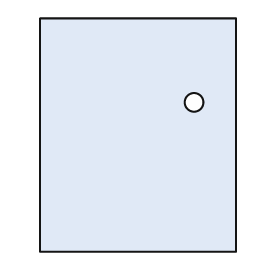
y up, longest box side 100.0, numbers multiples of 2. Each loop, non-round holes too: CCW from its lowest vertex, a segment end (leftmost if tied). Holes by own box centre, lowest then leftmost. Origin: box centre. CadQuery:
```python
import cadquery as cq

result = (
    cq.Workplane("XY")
    .moveTo(-42.0, -50.0)
    .lineTo(42.0, -50.0)
    .lineTo(42.0, 50.0)
    .lineTo(-42.0, 50.0)
    .close()
    .moveTo(24.0, 14.0)
    .circle(4.0)
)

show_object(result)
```